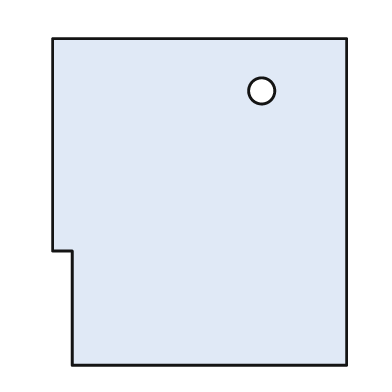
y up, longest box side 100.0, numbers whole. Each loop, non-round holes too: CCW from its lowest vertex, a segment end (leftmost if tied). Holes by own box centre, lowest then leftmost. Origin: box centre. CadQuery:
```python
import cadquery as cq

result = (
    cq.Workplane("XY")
    .moveTo(-39.0, -50.0)
    .lineTo(45.0, -50.0)
    .lineTo(45.0, 50.0)
    .lineTo(-45.0, 50.0)
    .lineTo(-45.0, -15.0)
    .lineTo(-39.0, -15.0)
    .close()
    .moveTo(19.0, 34.0)
    .circle(4.0)
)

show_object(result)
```